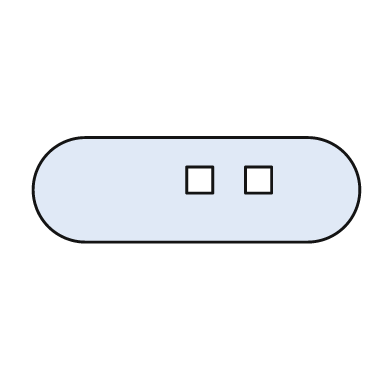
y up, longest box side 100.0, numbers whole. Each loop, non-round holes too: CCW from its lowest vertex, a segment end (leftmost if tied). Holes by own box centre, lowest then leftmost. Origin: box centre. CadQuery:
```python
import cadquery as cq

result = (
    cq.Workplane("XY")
    .moveTo(-34.0, -16.0)
    .lineTo(34.0, -16.0)
    .threePointArc((50.0, 0.0), (34.0, 16.0))
    .lineTo(-34.0, 16.0)
    .threePointArc((-50.0, 0.0), (-34.0, -16.0))
    .close()
    .moveTo(-3.0, -1.0)
    .lineTo(5.0, -1.0)
    .lineTo(5.0, 7.0)
    .lineTo(-3.0, 7.0)
    .close()
    .moveTo(15.0, -1.0)
    .lineTo(23.0, -1.0)
    .lineTo(23.0, 7.0)
    .lineTo(15.0, 7.0)
    .close()
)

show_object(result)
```